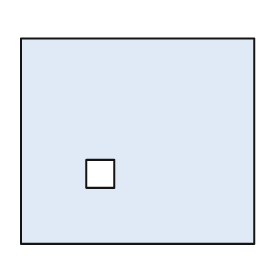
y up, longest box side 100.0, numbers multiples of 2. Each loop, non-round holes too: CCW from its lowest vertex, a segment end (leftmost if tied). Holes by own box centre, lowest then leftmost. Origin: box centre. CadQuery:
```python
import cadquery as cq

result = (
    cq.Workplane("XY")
    .moveTo(-50.0, -44.0)
    .lineTo(50.0, -44.0)
    .lineTo(50.0, 44.0)
    .lineTo(-50.0, 44.0)
    .close()
    .moveTo(-22.0, -20.0)
    .lineTo(-10.0, -20.0)
    .lineTo(-10.0, -8.0)
    .lineTo(-22.0, -8.0)
    .close()
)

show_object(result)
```